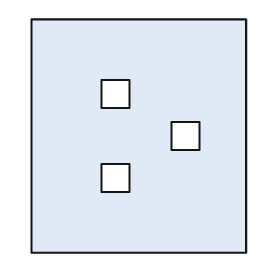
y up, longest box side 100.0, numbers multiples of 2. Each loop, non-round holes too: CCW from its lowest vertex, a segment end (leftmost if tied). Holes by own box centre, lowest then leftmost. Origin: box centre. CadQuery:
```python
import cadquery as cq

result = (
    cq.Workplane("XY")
    .moveTo(-46.0, -50.0)
    .lineTo(46.0, -50.0)
    .lineTo(46.0, 50.0)
    .lineTo(-46.0, 50.0)
    .close()
    .moveTo(-16.0, -24.0)
    .lineTo(-4.0, -24.0)
    .lineTo(-4.0, -12.0)
    .lineTo(-16.0, -12.0)
    .close()
    .moveTo(14.0, -6.0)
    .lineTo(26.0, -6.0)
    .lineTo(26.0, 6.0)
    .lineTo(14.0, 6.0)
    .close()
    .moveTo(-16.0, 12.0)
    .lineTo(-4.0, 12.0)
    .lineTo(-4.0, 24.0)
    .lineTo(-16.0, 24.0)
    .close()
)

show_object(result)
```